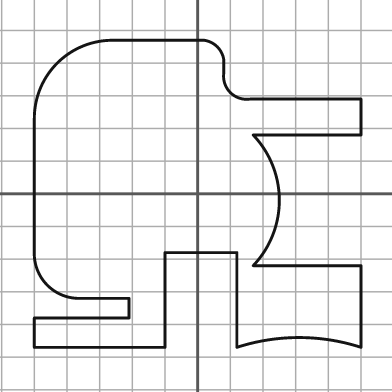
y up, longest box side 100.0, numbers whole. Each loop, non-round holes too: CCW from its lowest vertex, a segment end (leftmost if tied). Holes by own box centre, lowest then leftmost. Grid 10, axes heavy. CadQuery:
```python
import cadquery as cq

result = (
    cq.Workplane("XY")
    .moveTo(-50.0, -47.0)
    .lineTo(-10.0, -47.0)
    .lineTo(-10.0, -18.0)
    .lineTo(12.0, -18.0)
    .lineTo(12.0, -47.0)
    .threePointArc((31.0, -44.0), (50.0, -47.0))
    .lineTo(50.0, -22.0)
    .lineTo(17.0, -22.0)
    .threePointArc((25.0, -2.0), (17.0, 18.0))
    .lineTo(50.0, 18.0)
    .lineTo(50.0, 29.0)
    .lineTo(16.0, 29.0)
    .threePointArc((10.0, 31.0), (8.0, 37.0))
    .lineTo(8.0, 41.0)
    .threePointArc((6.0, 45.0), (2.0, 47.0))
    .lineTo(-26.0, 47.0)
    .threePointArc((-43.0, 40.0), (-50.0, 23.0))
    .lineTo(-50.0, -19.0)
    .threePointArc((-46.0, -28.0), (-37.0, -32.0))
    .lineTo(-21.0, -32.0)
    .lineTo(-21.0, -38.0)
    .lineTo(-50.0, -38.0)
    .close()
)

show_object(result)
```